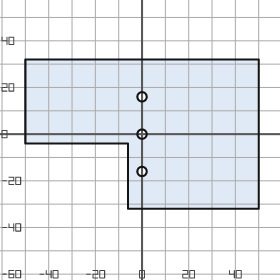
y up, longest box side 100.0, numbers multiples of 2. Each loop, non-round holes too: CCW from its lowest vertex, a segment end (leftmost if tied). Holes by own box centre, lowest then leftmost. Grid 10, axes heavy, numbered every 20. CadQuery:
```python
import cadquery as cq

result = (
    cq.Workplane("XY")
    .moveTo(-6.0, -32.0)
    .lineTo(50.0, -32.0)
    .lineTo(50.0, 32.0)
    .lineTo(-50.0, 32.0)
    .lineTo(-50.0, -4.0)
    .lineTo(-6.0, -4.0)
    .close()
    .moveTo(0.0, -16.0)
    .circle(2.0)
    .moveTo(0.0, 0.0)
    .circle(2.0)
    .moveTo(0.0, 16.0)
    .circle(2.0)
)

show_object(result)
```